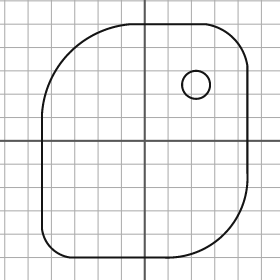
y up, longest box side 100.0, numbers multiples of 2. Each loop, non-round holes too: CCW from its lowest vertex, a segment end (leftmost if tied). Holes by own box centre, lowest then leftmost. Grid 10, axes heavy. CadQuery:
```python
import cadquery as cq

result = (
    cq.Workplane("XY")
    .moveTo(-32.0, -50.0)
    .lineTo(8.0, -50.0)
    .threePointArc((34.0, -40.0), (44.0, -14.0))
    .lineTo(44.0, 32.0)
    .threePointArc((38.0, 44.0), (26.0, 50.0))
    .lineTo(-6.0, 50.0)
    .threePointArc((-32.0, 38.0), (-44.0, 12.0))
    .lineTo(-44.0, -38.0)
    .threePointArc((-40.0, -46.0), (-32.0, -50.0))
    .close()
    .moveTo(22.0, 24.0)
    .circle(6.0)
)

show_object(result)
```